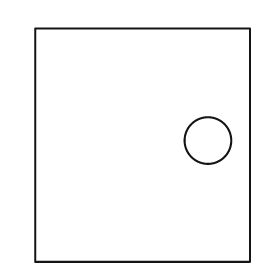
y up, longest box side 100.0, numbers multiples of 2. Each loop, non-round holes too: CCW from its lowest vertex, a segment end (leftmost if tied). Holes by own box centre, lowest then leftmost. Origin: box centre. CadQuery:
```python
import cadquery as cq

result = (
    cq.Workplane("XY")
    .moveTo(-46.0, -50.0)
    .lineTo(46.0, -50.0)
    .lineTo(46.0, 50.0)
    .lineTo(-46.0, 50.0)
    .close()
    .moveTo(28.0, 2.0)
    .circle(10.0)
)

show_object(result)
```